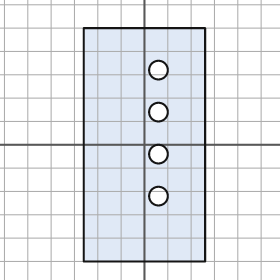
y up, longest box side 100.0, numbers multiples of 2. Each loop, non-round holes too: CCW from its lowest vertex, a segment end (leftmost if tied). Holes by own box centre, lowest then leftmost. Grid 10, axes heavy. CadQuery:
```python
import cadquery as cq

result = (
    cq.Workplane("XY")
    .moveTo(-26.0, -50.0)
    .lineTo(26.0, -50.0)
    .lineTo(26.0, 50.0)
    .lineTo(-26.0, 50.0)
    .close()
    .moveTo(6.0, -22.0)
    .circle(4.0)
    .moveTo(6.0, -4.0)
    .circle(4.0)
    .moveTo(6.0, 14.0)
    .circle(4.0)
    .moveTo(6.0, 32.0)
    .circle(4.0)
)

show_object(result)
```